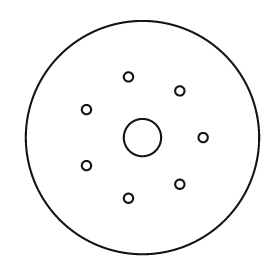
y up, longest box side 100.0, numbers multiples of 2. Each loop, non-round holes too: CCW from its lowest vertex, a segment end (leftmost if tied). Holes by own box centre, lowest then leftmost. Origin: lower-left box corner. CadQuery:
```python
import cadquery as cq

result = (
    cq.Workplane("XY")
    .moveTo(50.0, 50.0)
    .circle(50.0)
    .moveTo(44.0, 24.0)
    .circle(2.0)
    .moveTo(66.0, 30.0)
    .circle(2.0)
    .moveTo(26.0, 38.0)
    .circle(2.0)
    .moveTo(50.0, 50.0)
    .circle(8.0)
    .moveTo(76.0, 50.0)
    .circle(2.0)
    .moveTo(26.0, 62.0)
    .circle(2.0)
    .moveTo(66.0, 70.0)
    .circle(2.0)
    .moveTo(44.0, 76.0)
    .circle(2.0)
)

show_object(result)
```